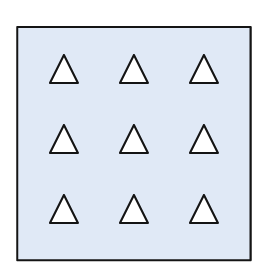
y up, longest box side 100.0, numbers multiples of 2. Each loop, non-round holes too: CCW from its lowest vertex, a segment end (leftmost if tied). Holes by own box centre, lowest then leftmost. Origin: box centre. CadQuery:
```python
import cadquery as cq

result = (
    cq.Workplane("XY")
    .moveTo(-50.0, -50.0)
    .lineTo(50.0, -50.0)
    .lineTo(50.0, 50.0)
    .lineTo(-50.0, 50.0)
    .close()
    .moveTo(-36.0, -34.0)
    .lineTo(-24.0, -34.0)
    .lineTo(-30.0, -22.0)
    .close()
    .moveTo(-6.0, -34.0)
    .lineTo(6.0, -34.0)
    .lineTo(0.0, -22.0)
    .close()
    .moveTo(24.0, -34.0)
    .lineTo(36.0, -34.0)
    .lineTo(30.0, -22.0)
    .close()
    .moveTo(-36.0, -4.0)
    .lineTo(-24.0, -4.0)
    .lineTo(-30.0, 8.0)
    .close()
    .moveTo(-6.0, -4.0)
    .lineTo(6.0, -4.0)
    .lineTo(0.0, 8.0)
    .close()
    .moveTo(24.0, -4.0)
    .lineTo(36.0, -4.0)
    .lineTo(30.0, 8.0)
    .close()
    .moveTo(-36.0, 26.0)
    .lineTo(-24.0, 26.0)
    .lineTo(-30.0, 38.0)
    .close()
    .moveTo(-6.0, 26.0)
    .lineTo(6.0, 26.0)
    .lineTo(0.0, 38.0)
    .close()
    .moveTo(24.0, 26.0)
    .lineTo(36.0, 26.0)
    .lineTo(30.0, 38.0)
    .close()
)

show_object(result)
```